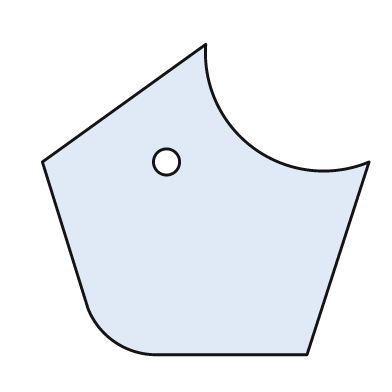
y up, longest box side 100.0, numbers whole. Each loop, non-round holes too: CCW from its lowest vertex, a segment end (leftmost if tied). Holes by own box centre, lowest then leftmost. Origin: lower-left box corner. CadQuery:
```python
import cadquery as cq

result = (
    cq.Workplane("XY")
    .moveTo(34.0, 0.0)
    .lineTo(81.0, 0.0)
    .lineTo(100.0, 59.0)
    .threePointArc((65.0, 63.0), (50.0, 95.0))
    .lineTo(0.0, 59.0)
    .lineTo(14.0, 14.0)
    .threePointArc((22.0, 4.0), (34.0, 0.0))
    .close()
    .moveTo(38.0, 59.0)
    .circle(4.0)
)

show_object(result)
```